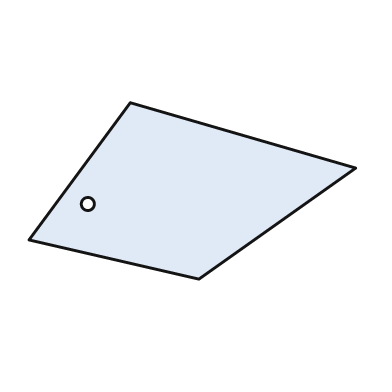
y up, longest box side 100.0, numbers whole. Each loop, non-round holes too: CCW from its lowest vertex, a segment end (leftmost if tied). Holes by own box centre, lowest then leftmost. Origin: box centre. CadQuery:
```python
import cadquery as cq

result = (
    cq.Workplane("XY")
    .moveTo(2.0, -27.0)
    .lineTo(50.0, 7.0)
    .lineTo(-19.0, 27.0)
    .lineTo(-50.0, -15.0)
    .close()
    .moveTo(-32.0, -4.0)
    .circle(2.0)
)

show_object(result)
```